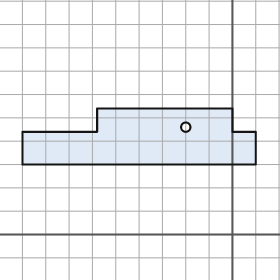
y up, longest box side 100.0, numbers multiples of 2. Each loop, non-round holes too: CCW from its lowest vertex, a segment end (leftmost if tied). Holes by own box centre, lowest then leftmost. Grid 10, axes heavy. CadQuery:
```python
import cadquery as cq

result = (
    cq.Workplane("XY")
    .moveTo(-90.0, 30.0)
    .lineTo(10.0, 30.0)
    .lineTo(10.0, 44.0)
    .lineTo(0.0, 44.0)
    .lineTo(0.0, 54.0)
    .lineTo(-58.0, 54.0)
    .lineTo(-58.0, 44.0)
    .lineTo(-90.0, 44.0)
    .close()
    .moveTo(-20.0, 46.0)
    .circle(2.0)
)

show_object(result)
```